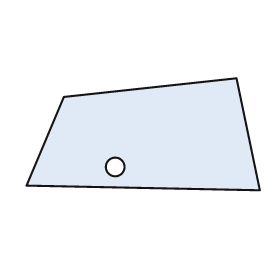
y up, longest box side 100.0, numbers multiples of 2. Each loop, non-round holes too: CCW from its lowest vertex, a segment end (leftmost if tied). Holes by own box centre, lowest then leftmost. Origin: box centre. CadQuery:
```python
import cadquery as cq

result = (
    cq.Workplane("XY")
    .moveTo(50.0, -24.0)
    .lineTo(40.0, 24.0)
    .lineTo(-34.0, 16.0)
    .lineTo(-50.0, -22.0)
    .close()
    .moveTo(-12.0, -14.0)
    .circle(4.0)
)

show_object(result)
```